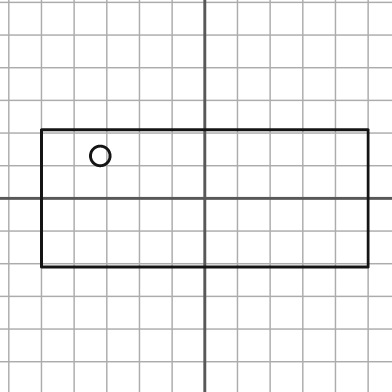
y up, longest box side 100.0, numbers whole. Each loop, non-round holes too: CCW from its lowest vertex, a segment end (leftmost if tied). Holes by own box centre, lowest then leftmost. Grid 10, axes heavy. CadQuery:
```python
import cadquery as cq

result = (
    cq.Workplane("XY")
    .moveTo(-50.0, -21.0)
    .lineTo(50.0, -21.0)
    .lineTo(50.0, 21.0)
    .lineTo(-50.0, 21.0)
    .close()
    .moveTo(-32.0, 13.0)
    .circle(3.0)
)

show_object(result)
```